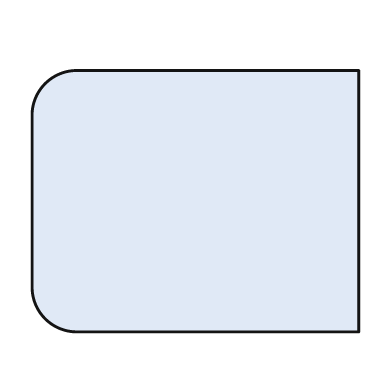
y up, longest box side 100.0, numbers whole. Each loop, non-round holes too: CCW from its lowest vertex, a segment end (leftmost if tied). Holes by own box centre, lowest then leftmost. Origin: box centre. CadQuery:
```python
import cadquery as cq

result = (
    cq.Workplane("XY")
    .moveTo(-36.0, -40.0)
    .lineTo(50.0, -40.0)
    .lineTo(50.0, 40.0)
    .lineTo(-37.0, 40.0)
    .threePointArc((-46.0, 36.0), (-50.0, 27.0))
    .lineTo(-50.0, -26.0)
    .threePointArc((-46.0, -36.0), (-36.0, -40.0))
    .close()
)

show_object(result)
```